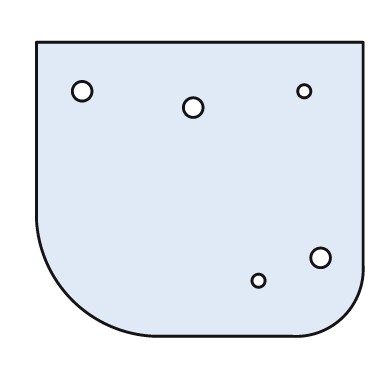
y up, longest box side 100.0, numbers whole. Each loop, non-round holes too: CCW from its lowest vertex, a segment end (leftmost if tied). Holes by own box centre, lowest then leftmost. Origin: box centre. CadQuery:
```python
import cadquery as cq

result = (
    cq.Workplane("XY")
    .moveTo(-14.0, -45.0)
    .lineTo(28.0, -45.0)
    .threePointArc((44.0, -39.0), (50.0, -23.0))
    .lineTo(50.0, 45.0)
    .lineTo(-50.0, 45.0)
    .lineTo(-50.0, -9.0)
    .threePointArc((-39.0, -34.0), (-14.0, -45.0))
    .close()
    .moveTo(18.0, -28.0)
    .circle(2.0)
    .moveTo(37.0, -21.0)
    .circle(3.0)
    .moveTo(-2.0, 25.0)
    .circle(3.0)
    .moveTo(-36.0, 30.0)
    .circle(3.0)
    .moveTo(32.0, 30.0)
    .circle(2.0)
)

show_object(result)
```